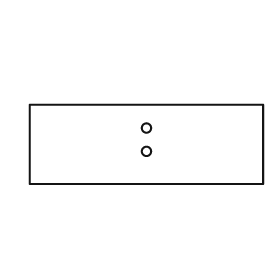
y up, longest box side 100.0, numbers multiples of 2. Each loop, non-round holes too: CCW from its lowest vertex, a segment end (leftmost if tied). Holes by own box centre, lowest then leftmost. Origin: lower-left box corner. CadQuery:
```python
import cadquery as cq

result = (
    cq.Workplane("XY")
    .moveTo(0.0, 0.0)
    .lineTo(100.0, 0.0)
    .lineTo(100.0, 34.0)
    .lineTo(0.0, 34.0)
    .close()
    .moveTo(50.0, 14.0)
    .circle(2.0)
    .moveTo(50.0, 24.0)
    .circle(2.0)
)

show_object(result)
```